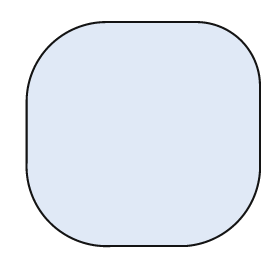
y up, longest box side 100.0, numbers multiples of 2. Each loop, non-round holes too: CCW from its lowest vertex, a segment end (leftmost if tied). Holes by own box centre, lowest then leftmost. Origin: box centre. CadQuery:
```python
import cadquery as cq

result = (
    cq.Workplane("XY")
    .moveTo(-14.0, -48.0)
    .lineTo(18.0, -48.0)
    .threePointArc((40.0, -38.0), (50.0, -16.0))
    .lineTo(50.0, 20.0)
    .threePointArc((42.0, 40.0), (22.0, 48.0))
    .lineTo(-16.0, 48.0)
    .threePointArc((-40.0, 38.0), (-50.0, 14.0))
    .lineTo(-50.0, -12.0)
    .threePointArc((-40.0, -38.0), (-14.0, -48.0))
    .close()
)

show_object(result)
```